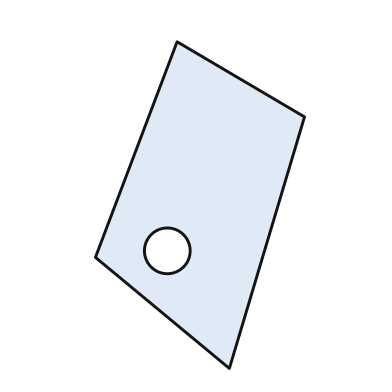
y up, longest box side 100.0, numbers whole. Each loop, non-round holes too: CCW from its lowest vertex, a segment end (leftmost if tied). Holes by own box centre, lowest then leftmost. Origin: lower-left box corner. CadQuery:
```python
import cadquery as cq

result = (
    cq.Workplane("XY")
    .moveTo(41.0, 0.0)
    .lineTo(64.0, 77.0)
    .lineTo(25.0, 100.0)
    .lineTo(0.0, 34.0)
    .close()
    .moveTo(22.0, 36.0)
    .circle(7.0)
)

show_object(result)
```